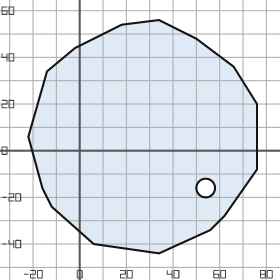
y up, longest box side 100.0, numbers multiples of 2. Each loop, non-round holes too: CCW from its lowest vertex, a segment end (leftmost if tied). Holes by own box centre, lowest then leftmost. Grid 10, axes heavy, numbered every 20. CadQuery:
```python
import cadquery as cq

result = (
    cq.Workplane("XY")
    .moveTo(34.0, -44.0)
    .lineTo(56.0, -34.0)
    .lineTo(62.0, -28.0)
    .lineTo(76.0, -8.0)
    .lineTo(76.0, 20.0)
    .lineTo(66.0, 36.0)
    .lineTo(50.0, 48.0)
    .lineTo(34.0, 56.0)
    .lineTo(18.0, 54.0)
    .lineTo(-2.0, 44.0)
    .lineTo(-14.0, 34.0)
    .lineTo(-22.0, 6.0)
    .lineTo(-16.0, -16.0)
    .lineTo(-12.0, -24.0)
    .lineTo(6.0, -40.0)
    .close()
    .moveTo(54.0, -16.0)
    .circle(4.0)
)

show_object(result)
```